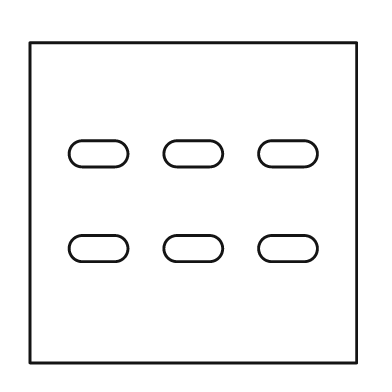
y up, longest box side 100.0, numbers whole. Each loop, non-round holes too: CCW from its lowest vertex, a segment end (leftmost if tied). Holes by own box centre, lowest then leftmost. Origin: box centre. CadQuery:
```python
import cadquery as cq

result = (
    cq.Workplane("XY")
    .moveTo(-50.0, -49.0)
    .lineTo(50.0, -49.0)
    .lineTo(50.0, 49.0)
    .lineTo(-50.0, 49.0)
    .close()
    .moveTo(-34.0, -18.0)
    .lineTo(-24.0, -18.0)
    .threePointArc((-20.0, -14.0), (-24.0, -10.0))
    .lineTo(-34.0, -10.0)
    .threePointArc((-38.0, -14.0), (-34.0, -18.0))
    .close()
    .moveTo(-5.0, -18.0)
    .lineTo(5.0, -18.0)
    .threePointArc((9.0, -14.0), (5.0, -10.0))
    .lineTo(-5.0, -10.0)
    .threePointArc((-9.0, -14.0), (-5.0, -18.0))
    .close()
    .moveTo(24.0, -18.0)
    .lineTo(34.0, -18.0)
    .threePointArc((38.0, -14.0), (34.0, -10.0))
    .lineTo(24.0, -10.0)
    .threePointArc((20.0, -14.0), (24.0, -18.0))
    .close()
    .moveTo(-34.0, 11.0)
    .lineTo(-24.0, 11.0)
    .threePointArc((-20.0, 15.0), (-24.0, 19.0))
    .lineTo(-34.0, 19.0)
    .threePointArc((-38.0, 15.0), (-34.0, 11.0))
    .close()
    .moveTo(-5.0, 11.0)
    .lineTo(5.0, 11.0)
    .threePointArc((9.0, 15.0), (5.0, 19.0))
    .lineTo(-5.0, 19.0)
    .threePointArc((-9.0, 15.0), (-5.0, 11.0))
    .close()
    .moveTo(24.0, 11.0)
    .lineTo(34.0, 11.0)
    .threePointArc((38.0, 15.0), (34.0, 19.0))
    .lineTo(24.0, 19.0)
    .threePointArc((20.0, 15.0), (24.0, 11.0))
    .close()
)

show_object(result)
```